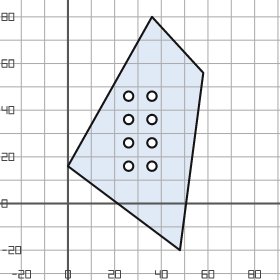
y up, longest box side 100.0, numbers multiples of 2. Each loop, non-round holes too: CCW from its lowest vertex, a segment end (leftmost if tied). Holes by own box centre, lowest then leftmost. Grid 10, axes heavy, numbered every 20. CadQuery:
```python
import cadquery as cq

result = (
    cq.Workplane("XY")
    .moveTo(48.0, -20.0)
    .lineTo(58.0, 56.0)
    .lineTo(36.0, 80.0)
    .lineTo(0.0, 16.0)
    .close()
    .moveTo(26.0, 16.0)
    .circle(2.0)
    .moveTo(36.0, 16.0)
    .circle(2.0)
    .moveTo(26.0, 26.0)
    .circle(2.0)
    .moveTo(36.0, 26.0)
    .circle(2.0)
    .moveTo(26.0, 36.0)
    .circle(2.0)
    .moveTo(36.0, 36.0)
    .circle(2.0)
    .moveTo(26.0, 46.0)
    .circle(2.0)
    .moveTo(36.0, 46.0)
    .circle(2.0)
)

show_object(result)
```